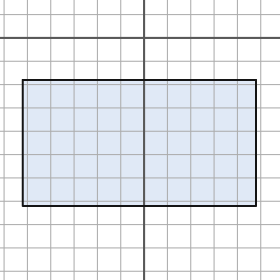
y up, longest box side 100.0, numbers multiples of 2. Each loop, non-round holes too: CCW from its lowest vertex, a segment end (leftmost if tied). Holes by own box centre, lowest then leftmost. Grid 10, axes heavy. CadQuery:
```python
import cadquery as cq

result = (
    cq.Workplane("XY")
    .moveTo(-52.0, -72.0)
    .lineTo(48.0, -72.0)
    .lineTo(48.0, -18.0)
    .lineTo(-52.0, -18.0)
    .close()
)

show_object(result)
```